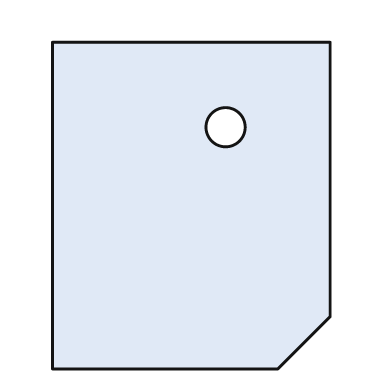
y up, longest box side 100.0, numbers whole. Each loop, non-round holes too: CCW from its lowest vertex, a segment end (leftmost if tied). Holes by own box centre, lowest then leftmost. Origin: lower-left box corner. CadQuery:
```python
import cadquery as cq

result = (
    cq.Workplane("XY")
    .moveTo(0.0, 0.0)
    .lineTo(69.0, 0.0)
    .lineTo(85.0, 16.0)
    .lineTo(85.0, 100.0)
    .lineTo(0.0, 100.0)
    .close()
    .moveTo(53.0, 74.0)
    .circle(6.0)
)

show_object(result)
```